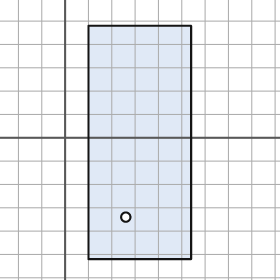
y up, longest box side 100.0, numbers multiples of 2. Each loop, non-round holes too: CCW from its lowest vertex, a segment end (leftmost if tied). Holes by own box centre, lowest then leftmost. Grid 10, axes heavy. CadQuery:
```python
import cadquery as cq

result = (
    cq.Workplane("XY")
    .moveTo(10.0, -52.0)
    .lineTo(54.0, -52.0)
    .lineTo(54.0, 48.0)
    .lineTo(10.0, 48.0)
    .close()
    .moveTo(26.0, -34.0)
    .circle(2.0)
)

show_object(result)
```